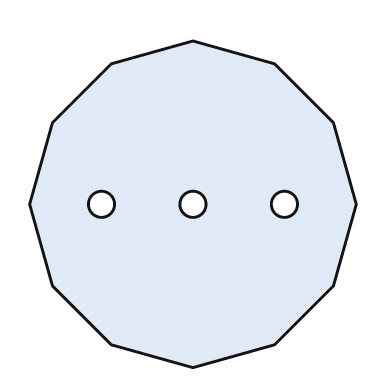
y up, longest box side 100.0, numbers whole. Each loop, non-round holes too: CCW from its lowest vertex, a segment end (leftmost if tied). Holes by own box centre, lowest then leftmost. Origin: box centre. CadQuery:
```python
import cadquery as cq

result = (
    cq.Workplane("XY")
    .moveTo(0.0, -50.0)
    .lineTo(25.0, -43.0)
    .lineTo(43.0, -25.0)
    .lineTo(50.0, 0.0)
    .lineTo(43.0, 25.0)
    .lineTo(25.0, 43.0)
    .lineTo(0.0, 50.0)
    .lineTo(-25.0, 43.0)
    .lineTo(-43.0, 25.0)
    .lineTo(-50.0, 0.0)
    .lineTo(-43.0, -25.0)
    .lineTo(-25.0, -43.0)
    .close()
    .moveTo(-28.0, 0.0)
    .circle(4.0)
    .moveTo(0.0, 0.0)
    .circle(4.0)
    .moveTo(28.0, 0.0)
    .circle(4.0)
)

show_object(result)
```